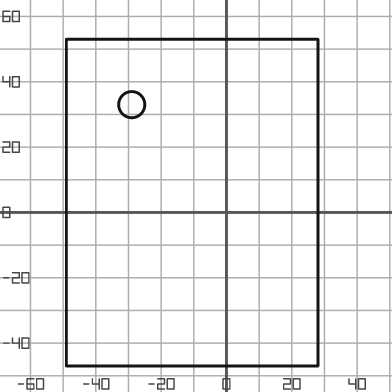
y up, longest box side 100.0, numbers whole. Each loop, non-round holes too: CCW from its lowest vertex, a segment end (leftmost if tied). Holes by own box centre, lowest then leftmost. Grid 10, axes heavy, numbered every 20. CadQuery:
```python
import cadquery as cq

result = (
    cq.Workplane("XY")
    .moveTo(-49.0, -47.0)
    .lineTo(28.0, -47.0)
    .lineTo(28.0, 53.0)
    .lineTo(-49.0, 53.0)
    .close()
    .moveTo(-29.0, 33.0)
    .circle(4.0)
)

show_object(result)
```